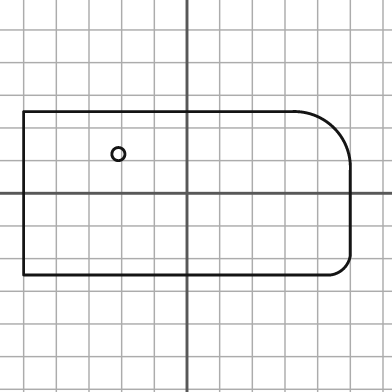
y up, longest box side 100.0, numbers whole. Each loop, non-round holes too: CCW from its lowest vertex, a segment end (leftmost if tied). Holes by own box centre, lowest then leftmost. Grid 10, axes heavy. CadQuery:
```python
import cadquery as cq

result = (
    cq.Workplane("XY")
    .moveTo(-50.0, -25.0)
    .lineTo(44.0, -25.0)
    .threePointArc((48.0, -23.0), (50.0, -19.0))
    .lineTo(50.0, 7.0)
    .threePointArc((45.0, 20.0), (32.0, 25.0))
    .lineTo(-50.0, 25.0)
    .close()
    .moveTo(-21.0, 12.0)
    .circle(2.0)
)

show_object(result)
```